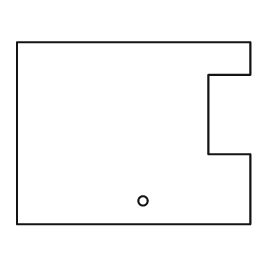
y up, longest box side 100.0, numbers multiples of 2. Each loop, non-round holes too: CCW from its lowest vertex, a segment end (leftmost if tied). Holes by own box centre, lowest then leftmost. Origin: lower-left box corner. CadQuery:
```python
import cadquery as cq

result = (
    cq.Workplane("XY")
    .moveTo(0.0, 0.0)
    .lineTo(100.0, 0.0)
    .lineTo(100.0, 30.0)
    .lineTo(82.0, 30.0)
    .lineTo(82.0, 64.0)
    .lineTo(100.0, 64.0)
    .lineTo(100.0, 78.0)
    .lineTo(0.0, 78.0)
    .close()
    .moveTo(54.0, 10.0)
    .circle(2.0)
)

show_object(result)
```